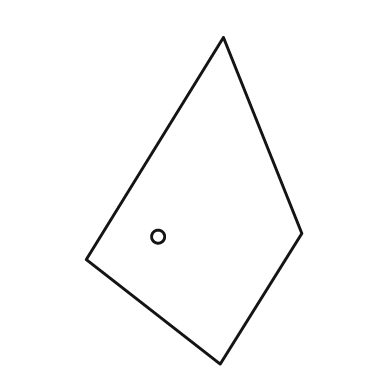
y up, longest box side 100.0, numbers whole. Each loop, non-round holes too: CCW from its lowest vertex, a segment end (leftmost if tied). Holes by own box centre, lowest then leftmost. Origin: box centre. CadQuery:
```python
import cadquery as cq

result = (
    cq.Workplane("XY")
    .moveTo(8.0, -50.0)
    .lineTo(33.0, -10.0)
    .lineTo(9.0, 50.0)
    .lineTo(-33.0, -18.0)
    .close()
    .moveTo(-11.0, -11.0)
    .circle(2.0)
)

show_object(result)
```